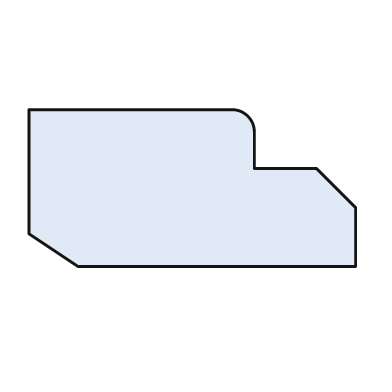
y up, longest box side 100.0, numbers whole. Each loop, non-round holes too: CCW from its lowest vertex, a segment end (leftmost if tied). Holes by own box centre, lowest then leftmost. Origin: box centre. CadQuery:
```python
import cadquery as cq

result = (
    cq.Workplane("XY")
    .moveTo(-35.0, -24.0)
    .lineTo(50.0, -24.0)
    .lineTo(50.0, -6.0)
    .lineTo(38.0, 6.0)
    .lineTo(19.0, 6.0)
    .lineTo(19.0, 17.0)
    .threePointArc((17.0, 22.0), (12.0, 24.0))
    .lineTo(-50.0, 24.0)
    .lineTo(-50.0, -14.0)
    .close()
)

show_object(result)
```